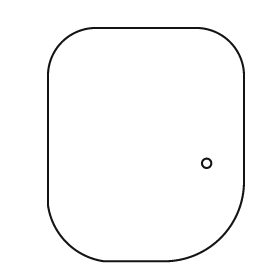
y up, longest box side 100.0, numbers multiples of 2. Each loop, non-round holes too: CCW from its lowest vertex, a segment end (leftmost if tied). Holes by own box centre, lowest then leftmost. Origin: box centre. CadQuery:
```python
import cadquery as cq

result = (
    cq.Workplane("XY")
    .moveTo(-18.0, -50.0)
    .lineTo(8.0, -50.0)
    .threePointArc((32.0, -40.0), (42.0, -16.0))
    .lineTo(42.0, 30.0)
    .threePointArc((36.0, 44.0), (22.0, 50.0))
    .lineTo(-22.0, 50.0)
    .threePointArc((-36.0, 44.0), (-42.0, 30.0))
    .lineTo(-42.0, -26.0)
    .threePointArc((-34.0, -42.0), (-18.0, -50.0))
    .close()
    .moveTo(26.0, -8.0)
    .circle(2.0)
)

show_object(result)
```